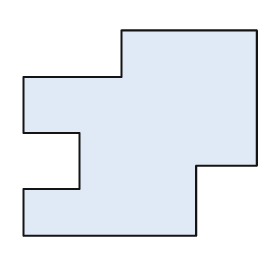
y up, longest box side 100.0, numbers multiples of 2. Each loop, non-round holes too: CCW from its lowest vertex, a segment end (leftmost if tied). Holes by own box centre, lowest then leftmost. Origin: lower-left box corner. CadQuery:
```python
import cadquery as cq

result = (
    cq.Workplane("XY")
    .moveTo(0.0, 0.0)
    .lineTo(74.0, 0.0)
    .lineTo(74.0, 30.0)
    .lineTo(100.0, 30.0)
    .lineTo(100.0, 88.0)
    .lineTo(42.0, 88.0)
    .lineTo(42.0, 68.0)
    .lineTo(0.0, 68.0)
    .lineTo(0.0, 44.0)
    .lineTo(24.0, 44.0)
    .lineTo(24.0, 20.0)
    .lineTo(0.0, 20.0)
    .close()
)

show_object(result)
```